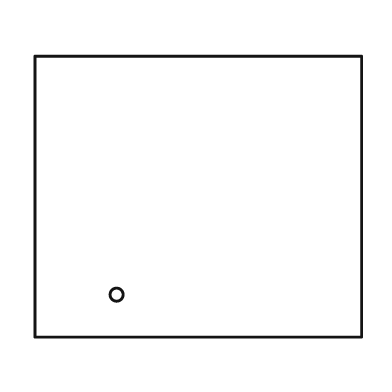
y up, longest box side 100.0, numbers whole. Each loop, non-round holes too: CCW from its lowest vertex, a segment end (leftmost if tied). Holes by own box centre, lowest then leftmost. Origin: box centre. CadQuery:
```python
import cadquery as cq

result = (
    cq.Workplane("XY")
    .moveTo(-50.0, -43.0)
    .lineTo(50.0, -43.0)
    .lineTo(50.0, 43.0)
    .lineTo(-50.0, 43.0)
    .close()
    .moveTo(-25.0, -30.0)
    .circle(2.0)
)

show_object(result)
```